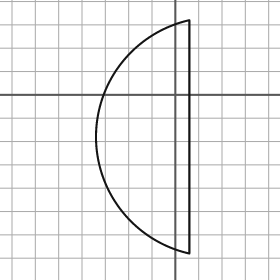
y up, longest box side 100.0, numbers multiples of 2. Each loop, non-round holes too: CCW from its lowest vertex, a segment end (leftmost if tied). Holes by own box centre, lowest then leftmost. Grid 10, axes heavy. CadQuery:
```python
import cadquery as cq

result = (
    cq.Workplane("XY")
    .moveTo(6.0, -68.0)
    .lineTo(6.0, 32.0)
    .threePointArc((-34.0, -18.0), (6.0, -68.0))
    .close()
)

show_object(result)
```